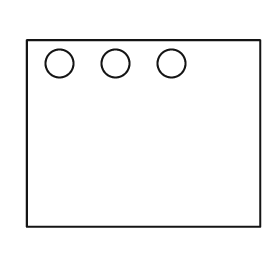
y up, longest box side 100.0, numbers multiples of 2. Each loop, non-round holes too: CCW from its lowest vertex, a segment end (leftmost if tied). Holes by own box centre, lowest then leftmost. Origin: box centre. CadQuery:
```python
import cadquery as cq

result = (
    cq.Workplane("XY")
    .moveTo(-50.0, -40.0)
    .lineTo(50.0, -40.0)
    .lineTo(50.0, 40.0)
    .lineTo(-50.0, 40.0)
    .close()
    .moveTo(-36.0, 30.0)
    .circle(6.0)
    .moveTo(-12.0, 30.0)
    .circle(6.0)
    .moveTo(12.0, 30.0)
    .circle(6.0)
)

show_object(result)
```